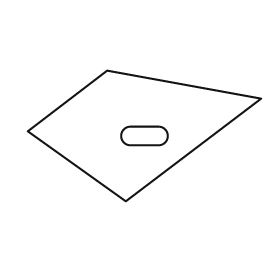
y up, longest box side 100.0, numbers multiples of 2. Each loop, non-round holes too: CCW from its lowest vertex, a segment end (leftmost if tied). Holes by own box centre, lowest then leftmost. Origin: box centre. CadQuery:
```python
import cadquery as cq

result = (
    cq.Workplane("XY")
    .moveTo(-8.0, -28.0)
    .lineTo(50.0, 16.0)
    .lineTo(-16.0, 28.0)
    .lineTo(-50.0, 2.0)
    .close()
    .moveTo(-6.0, -4.0)
    .lineTo(6.0, -4.0)
    .threePointArc((10.0, 0.0), (6.0, 4.0))
    .lineTo(-6.0, 4.0)
    .threePointArc((-10.0, 0.0), (-6.0, -4.0))
    .close()
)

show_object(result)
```